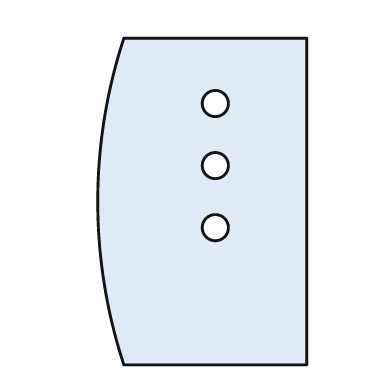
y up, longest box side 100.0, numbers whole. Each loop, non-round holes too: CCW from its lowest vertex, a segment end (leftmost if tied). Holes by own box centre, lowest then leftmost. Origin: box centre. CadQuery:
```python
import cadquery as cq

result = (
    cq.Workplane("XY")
    .moveTo(-24.0, -50.0)
    .lineTo(32.0, -50.0)
    .lineTo(32.0, 50.0)
    .lineTo(-24.0, 50.0)
    .threePointArc((-32.0, 0.0), (-24.0, -50.0))
    .close()
    .moveTo(4.0, -8.0)
    .circle(4.0)
    .moveTo(4.0, 11.0)
    .circle(4.0)
    .moveTo(4.0, 30.0)
    .circle(4.0)
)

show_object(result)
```